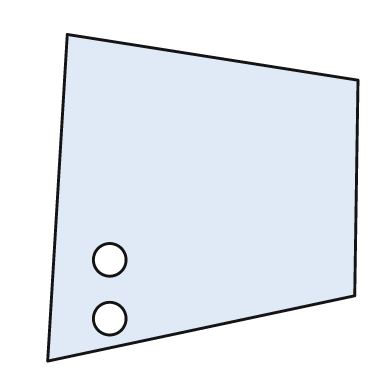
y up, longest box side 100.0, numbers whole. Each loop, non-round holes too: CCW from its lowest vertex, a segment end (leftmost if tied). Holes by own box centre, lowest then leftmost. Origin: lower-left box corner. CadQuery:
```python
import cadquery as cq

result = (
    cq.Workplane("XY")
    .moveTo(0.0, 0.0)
    .lineTo(94.0, 20.0)
    .lineTo(95.0, 86.0)
    .lineTo(6.0, 100.0)
    .close()
    .moveTo(19.0, 13.0)
    .circle(5.0)
    .moveTo(19.0, 31.0)
    .circle(5.0)
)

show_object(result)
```